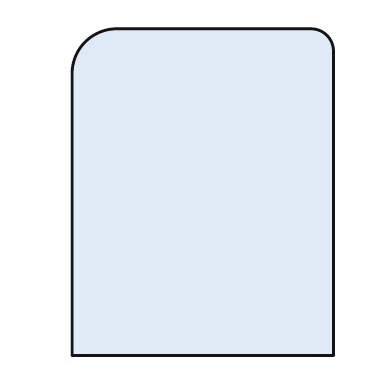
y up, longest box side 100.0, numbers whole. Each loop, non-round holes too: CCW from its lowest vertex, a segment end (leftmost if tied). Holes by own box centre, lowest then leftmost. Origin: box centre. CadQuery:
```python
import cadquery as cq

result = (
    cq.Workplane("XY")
    .moveTo(-40.0, -50.0)
    .lineTo(40.0, -50.0)
    .lineTo(40.0, 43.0)
    .threePointArc((38.0, 48.0), (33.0, 50.0))
    .lineTo(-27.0, 50.0)
    .threePointArc((-36.0, 46.0), (-40.0, 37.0))
    .close()
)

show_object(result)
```